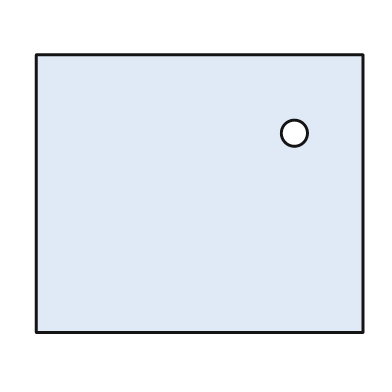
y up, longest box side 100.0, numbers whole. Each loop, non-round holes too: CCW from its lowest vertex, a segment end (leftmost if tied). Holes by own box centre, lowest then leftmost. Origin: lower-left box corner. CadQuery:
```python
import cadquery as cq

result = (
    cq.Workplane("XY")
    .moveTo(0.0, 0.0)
    .lineTo(100.0, 0.0)
    .lineTo(100.0, 85.0)
    .lineTo(0.0, 85.0)
    .close()
    .moveTo(79.0, 61.0)
    .circle(4.0)
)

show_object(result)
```